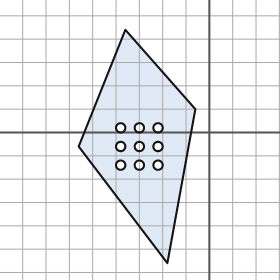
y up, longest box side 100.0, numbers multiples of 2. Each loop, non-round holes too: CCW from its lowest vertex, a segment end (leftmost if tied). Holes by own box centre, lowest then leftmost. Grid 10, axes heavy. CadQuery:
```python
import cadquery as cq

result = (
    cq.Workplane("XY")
    .moveTo(-18.0, -56.0)
    .lineTo(-6.0, 10.0)
    .lineTo(-36.0, 44.0)
    .lineTo(-56.0, -6.0)
    .close()
    .moveTo(-38.0, -14.0)
    .circle(2.0)
    .moveTo(-30.0, -14.0)
    .circle(2.0)
    .moveTo(-22.0, -14.0)
    .circle(2.0)
    .moveTo(-38.0, -6.0)
    .circle(2.0)
    .moveTo(-30.0, -6.0)
    .circle(2.0)
    .moveTo(-22.0, -6.0)
    .circle(2.0)
    .moveTo(-38.0, 2.0)
    .circle(2.0)
    .moveTo(-30.0, 2.0)
    .circle(2.0)
    .moveTo(-22.0, 2.0)
    .circle(2.0)
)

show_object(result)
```